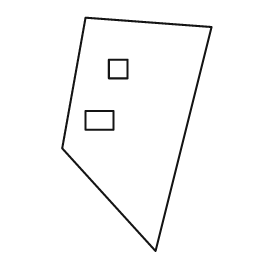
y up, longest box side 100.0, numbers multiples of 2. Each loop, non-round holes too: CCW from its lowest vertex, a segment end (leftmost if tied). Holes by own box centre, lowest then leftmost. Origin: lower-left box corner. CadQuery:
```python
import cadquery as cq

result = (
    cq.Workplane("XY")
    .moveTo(40.0, 0.0)
    .lineTo(64.0, 96.0)
    .lineTo(10.0, 100.0)
    .lineTo(0.0, 44.0)
    .close()
    .moveTo(10.0, 52.0)
    .lineTo(22.0, 52.0)
    .lineTo(22.0, 60.0)
    .lineTo(10.0, 60.0)
    .close()
    .moveTo(20.0, 74.0)
    .lineTo(28.0, 74.0)
    .lineTo(28.0, 82.0)
    .lineTo(20.0, 82.0)
    .close()
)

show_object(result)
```